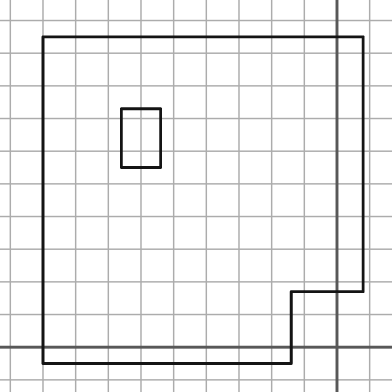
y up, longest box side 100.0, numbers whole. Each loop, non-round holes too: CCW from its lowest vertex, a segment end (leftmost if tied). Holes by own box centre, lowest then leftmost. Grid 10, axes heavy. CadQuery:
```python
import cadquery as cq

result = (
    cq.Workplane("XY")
    .moveTo(-90.0, -5.0)
    .lineTo(-14.0, -5.0)
    .lineTo(-14.0, 17.0)
    .lineTo(8.0, 17.0)
    .lineTo(8.0, 95.0)
    .lineTo(-90.0, 95.0)
    .close()
    .moveTo(-66.0, 55.0)
    .lineTo(-54.0, 55.0)
    .lineTo(-54.0, 73.0)
    .lineTo(-66.0, 73.0)
    .close()
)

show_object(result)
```